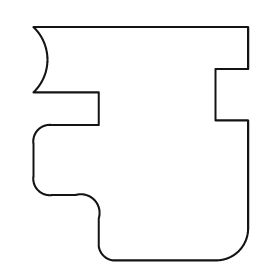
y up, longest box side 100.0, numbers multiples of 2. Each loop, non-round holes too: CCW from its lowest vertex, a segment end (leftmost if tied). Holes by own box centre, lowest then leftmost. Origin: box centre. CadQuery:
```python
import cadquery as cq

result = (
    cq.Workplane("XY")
    .moveTo(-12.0, -50.0)
    .lineTo(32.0, -50.0)
    .threePointArc((42.0, -46.0), (46.0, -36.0))
    .lineTo(46.0, 10.0)
    .lineTo(32.0, 10.0)
    .lineTo(32.0, 32.0)
    .lineTo(46.0, 32.0)
    .lineTo(46.0, 50.0)
    .lineTo(-46.0, 50.0)
    .threePointArc((-40.0, 36.0), (-46.0, 22.0))
    .lineTo(-18.0, 22.0)
    .lineTo(-18.0, 8.0)
    .lineTo(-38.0, 8.0)
    .threePointArc((-44.0, 6.0), (-46.0, 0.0))
    .lineTo(-46.0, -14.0)
    .threePointArc((-44.0, -20.0), (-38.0, -22.0))
    .lineTo(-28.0, -22.0)
    .threePointArc((-20.0, -24.0), (-18.0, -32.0))
    .lineTo(-18.0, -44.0)
    .threePointArc((-16.0, -48.0), (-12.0, -50.0))
    .close()
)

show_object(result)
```